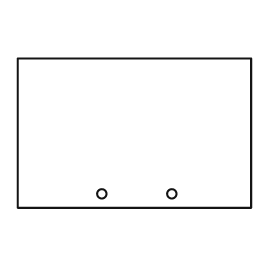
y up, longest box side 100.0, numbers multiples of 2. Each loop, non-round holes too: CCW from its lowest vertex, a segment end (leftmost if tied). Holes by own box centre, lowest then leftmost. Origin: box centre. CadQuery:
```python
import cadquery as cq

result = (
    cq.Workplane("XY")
    .moveTo(-50.0, -32.0)
    .lineTo(50.0, -32.0)
    .lineTo(50.0, 32.0)
    .lineTo(-50.0, 32.0)
    .close()
    .moveTo(-14.0, -26.0)
    .circle(2.0)
    .moveTo(16.0, -26.0)
    .circle(2.0)
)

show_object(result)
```